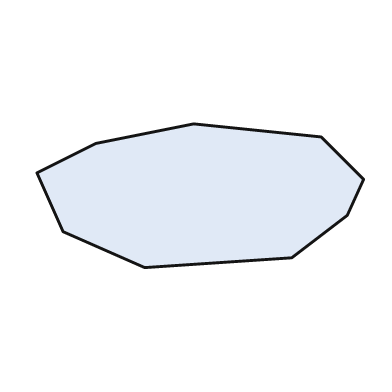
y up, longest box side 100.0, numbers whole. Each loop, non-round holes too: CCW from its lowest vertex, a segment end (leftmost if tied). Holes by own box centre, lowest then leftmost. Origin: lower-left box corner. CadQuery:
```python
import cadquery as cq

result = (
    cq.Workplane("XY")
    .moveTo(33.0, 0.0)
    .lineTo(78.0, 3.0)
    .lineTo(95.0, 16.0)
    .lineTo(100.0, 27.0)
    .lineTo(87.0, 40.0)
    .lineTo(48.0, 44.0)
    .lineTo(18.0, 38.0)
    .lineTo(0.0, 29.0)
    .lineTo(8.0, 11.0)
    .close()
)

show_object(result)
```